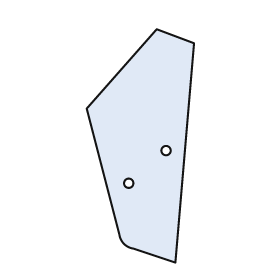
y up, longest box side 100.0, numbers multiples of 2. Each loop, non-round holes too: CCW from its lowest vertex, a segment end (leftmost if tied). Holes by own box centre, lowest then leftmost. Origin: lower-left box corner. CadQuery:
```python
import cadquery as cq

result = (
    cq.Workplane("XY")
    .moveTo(38.0, 0.0)
    .lineTo(46.0, 94.0)
    .lineTo(30.0, 100.0)
    .lineTo(0.0, 66.0)
    .lineTo(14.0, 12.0)
    .threePointArc((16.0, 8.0), (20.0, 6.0))
    .close()
    .moveTo(18.0, 34.0)
    .circle(2.0)
    .moveTo(34.0, 48.0)
    .circle(2.0)
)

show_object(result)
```